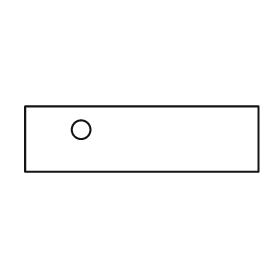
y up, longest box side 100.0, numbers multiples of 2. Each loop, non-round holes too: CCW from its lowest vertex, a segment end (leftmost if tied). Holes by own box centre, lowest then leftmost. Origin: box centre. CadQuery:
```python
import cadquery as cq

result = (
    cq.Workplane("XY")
    .moveTo(-50.0, -14.0)
    .lineTo(50.0, -14.0)
    .lineTo(50.0, 14.0)
    .lineTo(-50.0, 14.0)
    .close()
    .moveTo(-26.0, 4.0)
    .circle(4.0)
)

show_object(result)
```